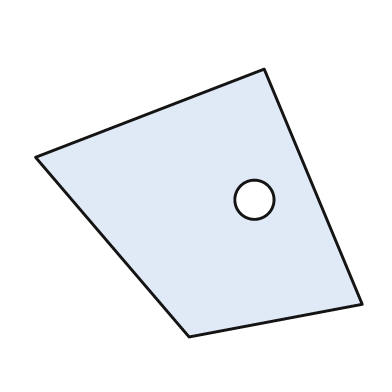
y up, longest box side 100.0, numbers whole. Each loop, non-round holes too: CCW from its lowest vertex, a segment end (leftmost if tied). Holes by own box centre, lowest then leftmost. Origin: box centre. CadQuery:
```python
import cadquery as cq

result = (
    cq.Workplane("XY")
    .moveTo(-3.0, -41.0)
    .lineTo(50.0, -31.0)
    .lineTo(20.0, 41.0)
    .lineTo(-50.0, 14.0)
    .close()
    .moveTo(17.0, 1.0)
    .circle(6.0)
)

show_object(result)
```